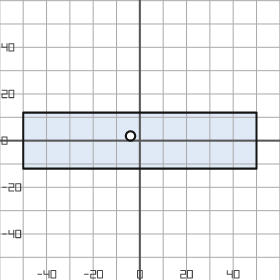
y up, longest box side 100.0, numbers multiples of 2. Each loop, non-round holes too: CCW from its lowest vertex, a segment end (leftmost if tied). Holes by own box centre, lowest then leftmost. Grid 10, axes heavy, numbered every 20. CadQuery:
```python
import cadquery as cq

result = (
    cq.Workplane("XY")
    .moveTo(-50.0, -12.0)
    .lineTo(50.0, -12.0)
    .lineTo(50.0, 12.0)
    .lineTo(-50.0, 12.0)
    .close()
    .moveTo(-4.0, 2.0)
    .circle(2.0)
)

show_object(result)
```